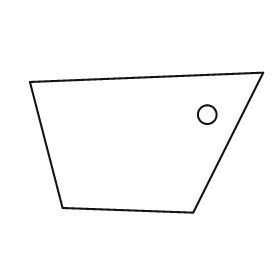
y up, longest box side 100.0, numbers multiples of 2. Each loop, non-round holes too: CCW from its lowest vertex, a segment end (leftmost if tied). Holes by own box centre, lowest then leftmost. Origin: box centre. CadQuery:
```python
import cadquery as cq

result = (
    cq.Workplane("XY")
    .moveTo(20.0, -30.0)
    .lineTo(50.0, 30.0)
    .lineTo(-50.0, 26.0)
    .lineTo(-36.0, -28.0)
    .close()
    .moveTo(26.0, 12.0)
    .circle(4.0)
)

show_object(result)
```